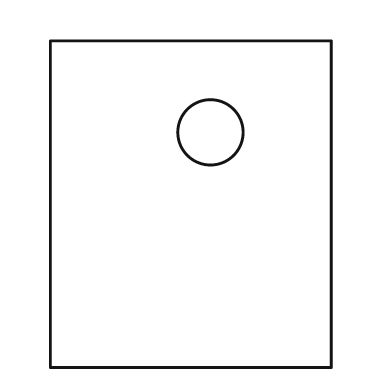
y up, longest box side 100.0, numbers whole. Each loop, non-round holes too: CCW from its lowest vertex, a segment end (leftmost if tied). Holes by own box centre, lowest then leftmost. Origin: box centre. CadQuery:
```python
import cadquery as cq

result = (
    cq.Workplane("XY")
    .moveTo(-43.0, -50.0)
    .lineTo(43.0, -50.0)
    .lineTo(43.0, 50.0)
    .lineTo(-43.0, 50.0)
    .close()
    .moveTo(6.0, 22.0)
    .circle(10.0)
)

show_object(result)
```